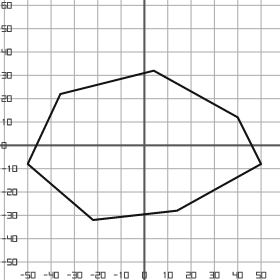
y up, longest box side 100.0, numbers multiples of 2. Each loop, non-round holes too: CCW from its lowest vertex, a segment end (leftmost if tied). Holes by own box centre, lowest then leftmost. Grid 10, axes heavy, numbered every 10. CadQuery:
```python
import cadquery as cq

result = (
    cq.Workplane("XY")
    .moveTo(-22.0, -32.0)
    .lineTo(14.0, -28.0)
    .lineTo(50.0, -8.0)
    .lineTo(40.0, 12.0)
    .lineTo(4.0, 32.0)
    .lineTo(-36.0, 22.0)
    .lineTo(-50.0, -8.0)
    .close()
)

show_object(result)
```